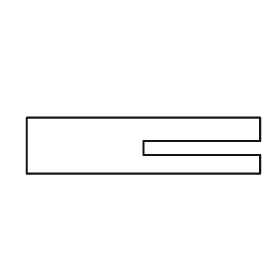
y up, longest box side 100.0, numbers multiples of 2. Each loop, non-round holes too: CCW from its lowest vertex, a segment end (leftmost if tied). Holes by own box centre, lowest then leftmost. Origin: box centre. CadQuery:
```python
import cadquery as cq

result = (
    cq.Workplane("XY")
    .moveTo(-50.0, -12.0)
    .lineTo(50.0, -12.0)
    .lineTo(50.0, -4.0)
    .lineTo(0.0, -4.0)
    .lineTo(0.0, 2.0)
    .lineTo(50.0, 2.0)
    .lineTo(50.0, 12.0)
    .lineTo(-50.0, 12.0)
    .close()
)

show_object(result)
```